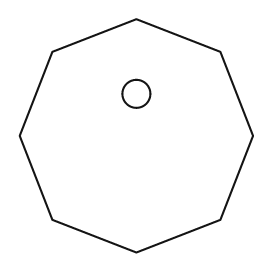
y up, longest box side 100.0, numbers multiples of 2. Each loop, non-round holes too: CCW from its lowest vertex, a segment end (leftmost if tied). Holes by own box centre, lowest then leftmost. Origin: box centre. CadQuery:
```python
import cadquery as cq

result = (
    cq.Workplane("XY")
    .moveTo(0.0, -50.0)
    .lineTo(36.0, -36.0)
    .lineTo(50.0, 0.0)
    .lineTo(36.0, 36.0)
    .lineTo(0.0, 50.0)
    .lineTo(-36.0, 36.0)
    .lineTo(-50.0, 0.0)
    .lineTo(-36.0, -36.0)
    .close()
    .moveTo(0.0, 18.0)
    .circle(6.0)
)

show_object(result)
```